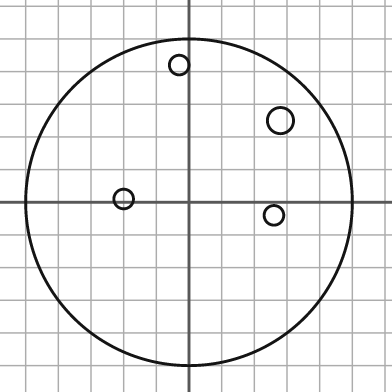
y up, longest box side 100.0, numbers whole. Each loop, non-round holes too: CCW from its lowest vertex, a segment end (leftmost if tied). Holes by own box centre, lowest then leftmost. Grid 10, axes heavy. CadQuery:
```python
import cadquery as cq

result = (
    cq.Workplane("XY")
    .moveTo(0.0, 0.0)
    .circle(50.0)
    .moveTo(26.0, -4.0)
    .circle(3.0)
    .moveTo(-20.0, 1.0)
    .circle(3.0)
    .moveTo(28.0, 25.0)
    .circle(4.0)
    .moveTo(-3.0, 42.0)
    .circle(3.0)
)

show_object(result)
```